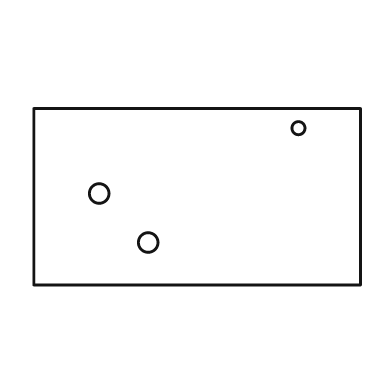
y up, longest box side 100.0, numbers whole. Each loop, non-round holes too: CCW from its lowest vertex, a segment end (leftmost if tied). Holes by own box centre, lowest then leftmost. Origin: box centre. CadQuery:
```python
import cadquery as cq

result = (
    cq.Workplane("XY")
    .moveTo(-50.0, -27.0)
    .lineTo(50.0, -27.0)
    .lineTo(50.0, 27.0)
    .lineTo(-50.0, 27.0)
    .close()
    .moveTo(-15.0, -14.0)
    .circle(3.0)
    .moveTo(-30.0, 1.0)
    .circle(3.0)
    .moveTo(31.0, 21.0)
    .circle(2.0)
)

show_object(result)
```